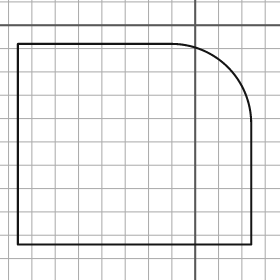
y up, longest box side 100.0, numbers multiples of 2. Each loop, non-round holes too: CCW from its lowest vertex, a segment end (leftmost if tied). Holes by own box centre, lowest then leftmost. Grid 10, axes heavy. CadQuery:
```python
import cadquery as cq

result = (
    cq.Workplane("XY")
    .moveTo(-76.0, -94.0)
    .lineTo(24.0, -94.0)
    .lineTo(24.0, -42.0)
    .threePointArc((14.0, -18.0), (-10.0, -8.0))
    .lineTo(-76.0, -8.0)
    .close()
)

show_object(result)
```